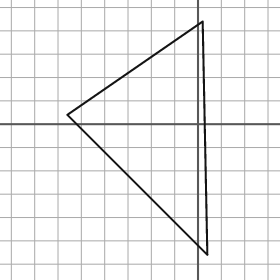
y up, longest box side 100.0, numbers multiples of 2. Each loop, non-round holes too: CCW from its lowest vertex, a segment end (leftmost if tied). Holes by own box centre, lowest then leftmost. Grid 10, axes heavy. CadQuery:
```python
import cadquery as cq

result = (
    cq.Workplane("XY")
    .moveTo(4.0, -56.0)
    .lineTo(2.0, 44.0)
    .lineTo(-56.0, 4.0)
    .close()
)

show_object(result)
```